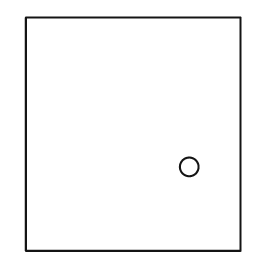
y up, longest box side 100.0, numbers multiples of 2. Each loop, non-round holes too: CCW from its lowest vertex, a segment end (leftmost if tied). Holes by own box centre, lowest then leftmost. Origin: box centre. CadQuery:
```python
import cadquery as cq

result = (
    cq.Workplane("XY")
    .moveTo(-46.0, -50.0)
    .lineTo(46.0, -50.0)
    .lineTo(46.0, 50.0)
    .lineTo(-46.0, 50.0)
    .close()
    .moveTo(24.0, -14.0)
    .circle(4.0)
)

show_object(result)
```